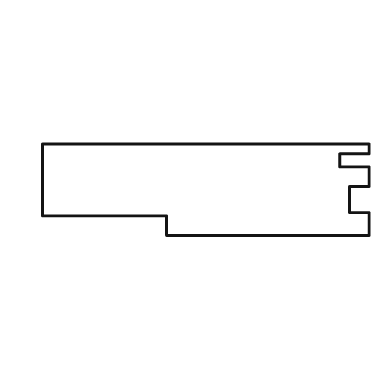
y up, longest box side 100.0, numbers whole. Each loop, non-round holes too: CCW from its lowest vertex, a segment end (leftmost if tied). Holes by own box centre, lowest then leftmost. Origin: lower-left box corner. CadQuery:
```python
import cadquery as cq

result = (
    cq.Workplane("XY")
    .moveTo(38.0, 0.0)
    .lineTo(100.0, 0.0)
    .lineTo(100.0, 7.0)
    .lineTo(94.0, 7.0)
    .lineTo(94.0, 15.0)
    .lineTo(100.0, 15.0)
    .lineTo(100.0, 21.0)
    .lineTo(91.0, 21.0)
    .lineTo(91.0, 25.0)
    .lineTo(100.0, 25.0)
    .lineTo(100.0, 28.0)
    .lineTo(0.0, 28.0)
    .lineTo(0.0, 6.0)
    .lineTo(38.0, 6.0)
    .close()
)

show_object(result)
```